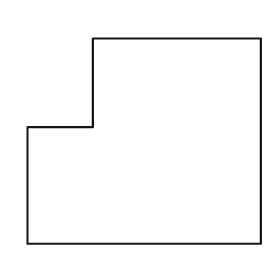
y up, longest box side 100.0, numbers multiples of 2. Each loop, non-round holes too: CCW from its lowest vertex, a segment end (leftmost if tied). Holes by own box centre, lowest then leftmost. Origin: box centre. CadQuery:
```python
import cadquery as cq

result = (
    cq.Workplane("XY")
    .moveTo(-50.0, -44.0)
    .lineTo(50.0, -44.0)
    .lineTo(50.0, 44.0)
    .lineTo(-22.0, 44.0)
    .lineTo(-22.0, 6.0)
    .lineTo(-50.0, 6.0)
    .close()
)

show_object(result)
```